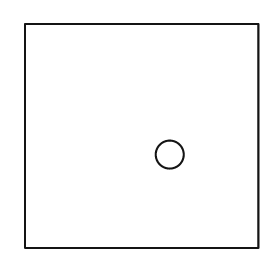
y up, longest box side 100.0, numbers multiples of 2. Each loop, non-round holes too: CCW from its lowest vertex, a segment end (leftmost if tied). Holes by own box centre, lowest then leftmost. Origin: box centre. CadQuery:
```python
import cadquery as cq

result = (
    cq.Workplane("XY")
    .moveTo(-50.0, -48.0)
    .lineTo(50.0, -48.0)
    .lineTo(50.0, 48.0)
    .lineTo(-50.0, 48.0)
    .close()
    .moveTo(12.0, -8.0)
    .circle(6.0)
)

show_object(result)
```